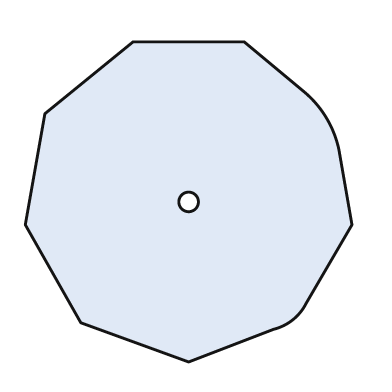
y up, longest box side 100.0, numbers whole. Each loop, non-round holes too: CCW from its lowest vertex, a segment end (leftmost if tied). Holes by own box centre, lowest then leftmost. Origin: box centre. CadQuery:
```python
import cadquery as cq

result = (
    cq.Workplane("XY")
    .moveTo(0.0, -49.0)
    .lineTo(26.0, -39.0)
    .threePointArc((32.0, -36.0), (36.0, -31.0))
    .lineTo(50.0, -7.0)
    .lineTo(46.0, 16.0)
    .threePointArc((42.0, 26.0), (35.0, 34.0))
    .lineTo(17.0, 49.0)
    .lineTo(-17.0, 49.0)
    .lineTo(-44.0, 27.0)
    .lineTo(-50.0, -7.0)
    .lineTo(-33.0, -37.0)
    .close()
    .moveTo(0.0, 0.0)
    .circle(3.0)
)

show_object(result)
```